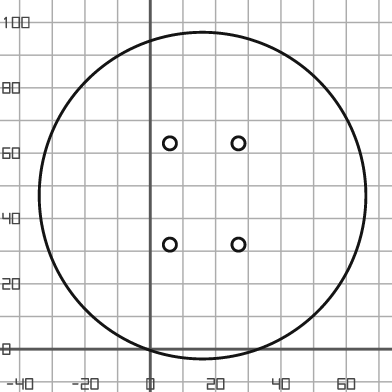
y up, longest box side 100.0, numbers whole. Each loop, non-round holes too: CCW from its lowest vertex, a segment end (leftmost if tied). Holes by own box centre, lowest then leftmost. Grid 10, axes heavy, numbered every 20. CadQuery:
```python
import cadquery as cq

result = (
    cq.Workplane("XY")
    .moveTo(16.0, 47.0)
    .circle(50.0)
    .moveTo(6.0, 32.0)
    .circle(2.0)
    .moveTo(27.0, 32.0)
    .circle(2.0)
    .moveTo(6.0, 63.0)
    .circle(2.0)
    .moveTo(27.0, 63.0)
    .circle(2.0)
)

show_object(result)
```